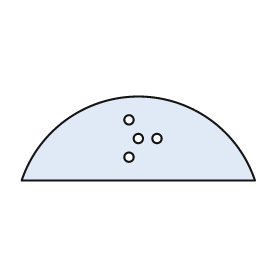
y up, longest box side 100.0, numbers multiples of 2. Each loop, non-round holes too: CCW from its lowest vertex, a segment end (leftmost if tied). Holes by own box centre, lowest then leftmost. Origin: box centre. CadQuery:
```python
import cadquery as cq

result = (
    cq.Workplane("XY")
    .moveTo(-50.0, -18.0)
    .lineTo(50.0, -18.0)
    .threePointArc((0.0, 18.0), (-50.0, -18.0))
    .close()
    .moveTo(-4.0, -8.0)
    .circle(2.0)
    .moveTo(0.0, 0.0)
    .circle(2.0)
    .moveTo(8.0, 0.0)
    .circle(2.0)
    .moveTo(-4.0, 8.0)
    .circle(2.0)
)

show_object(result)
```